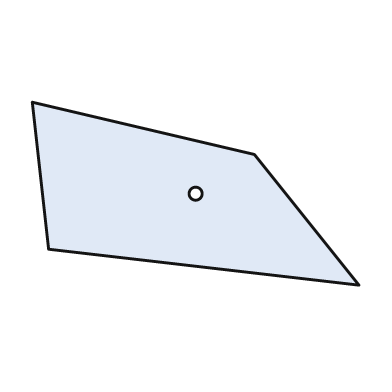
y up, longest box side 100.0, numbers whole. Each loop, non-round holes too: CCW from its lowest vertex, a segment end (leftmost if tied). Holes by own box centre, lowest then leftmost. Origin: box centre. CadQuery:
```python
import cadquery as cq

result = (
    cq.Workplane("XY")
    .moveTo(50.0, -28.0)
    .lineTo(18.0, 12.0)
    .lineTo(-50.0, 28.0)
    .lineTo(-45.0, -17.0)
    .close()
    .moveTo(0.0, 0.0)
    .circle(2.0)
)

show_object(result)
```